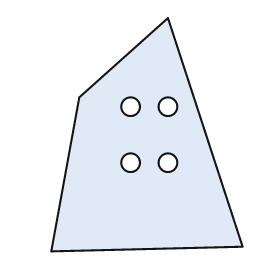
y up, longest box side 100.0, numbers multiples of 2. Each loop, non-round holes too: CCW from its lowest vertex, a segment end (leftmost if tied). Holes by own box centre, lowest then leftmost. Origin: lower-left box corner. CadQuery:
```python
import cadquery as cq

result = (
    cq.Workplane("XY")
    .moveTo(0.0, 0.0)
    .lineTo(82.0, 2.0)
    .lineTo(50.0, 100.0)
    .lineTo(12.0, 66.0)
    .close()
    .moveTo(34.0, 38.0)
    .circle(4.0)
    .moveTo(50.0, 38.0)
    .circle(4.0)
    .moveTo(34.0, 62.0)
    .circle(4.0)
    .moveTo(50.0, 62.0)
    .circle(4.0)
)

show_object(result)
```